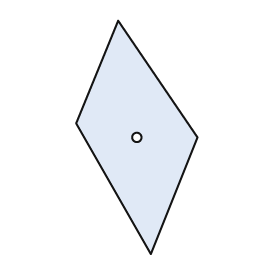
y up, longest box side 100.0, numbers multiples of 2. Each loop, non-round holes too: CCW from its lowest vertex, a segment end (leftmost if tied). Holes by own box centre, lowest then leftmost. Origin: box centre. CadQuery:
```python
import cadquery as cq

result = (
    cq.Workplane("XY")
    .moveTo(6.0, -50.0)
    .lineTo(26.0, 0.0)
    .lineTo(-8.0, 50.0)
    .lineTo(-26.0, 6.0)
    .close()
    .moveTo(0.0, 0.0)
    .circle(2.0)
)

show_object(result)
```